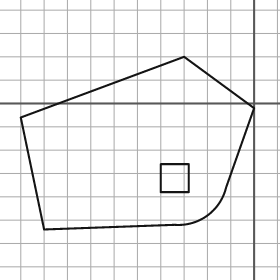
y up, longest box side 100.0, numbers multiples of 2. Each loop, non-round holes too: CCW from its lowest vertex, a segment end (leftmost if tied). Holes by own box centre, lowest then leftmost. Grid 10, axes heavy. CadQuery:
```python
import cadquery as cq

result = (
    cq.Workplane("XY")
    .moveTo(-90.0, -54.0)
    .lineTo(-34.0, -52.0)
    .threePointArc((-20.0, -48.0), (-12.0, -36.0))
    .lineTo(0.0, -2.0)
    .lineTo(-30.0, 20.0)
    .lineTo(-100.0, -6.0)
    .close()
    .moveTo(-40.0, -38.0)
    .lineTo(-28.0, -38.0)
    .lineTo(-28.0, -26.0)
    .lineTo(-40.0, -26.0)
    .close()
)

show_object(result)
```